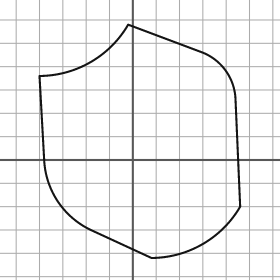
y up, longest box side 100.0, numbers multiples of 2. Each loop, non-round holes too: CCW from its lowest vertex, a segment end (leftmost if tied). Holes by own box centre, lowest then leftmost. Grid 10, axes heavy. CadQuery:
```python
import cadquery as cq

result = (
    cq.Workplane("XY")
    .moveTo(8.0, -42.0)
    .threePointArc((30.0, -36.0), (46.0, -20.0))
    .lineTo(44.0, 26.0)
    .threePointArc((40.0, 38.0), (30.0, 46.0))
    .lineTo(-2.0, 58.0)
    .threePointArc((-18.0, 42.0), (-40.0, 36.0))
    .lineTo(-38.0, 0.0)
    .threePointArc((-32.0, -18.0), (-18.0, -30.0))
    .close()
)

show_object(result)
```